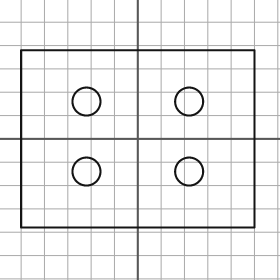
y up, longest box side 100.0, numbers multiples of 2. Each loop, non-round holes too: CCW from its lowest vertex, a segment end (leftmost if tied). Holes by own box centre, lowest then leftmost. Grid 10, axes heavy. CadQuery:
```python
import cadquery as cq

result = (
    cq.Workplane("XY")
    .moveTo(-50.0, -38.0)
    .lineTo(50.0, -38.0)
    .lineTo(50.0, 38.0)
    .lineTo(-50.0, 38.0)
    .close()
    .moveTo(-22.0, -14.0)
    .circle(6.0)
    .moveTo(22.0, -14.0)
    .circle(6.0)
    .moveTo(-22.0, 16.0)
    .circle(6.0)
    .moveTo(22.0, 16.0)
    .circle(6.0)
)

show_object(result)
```